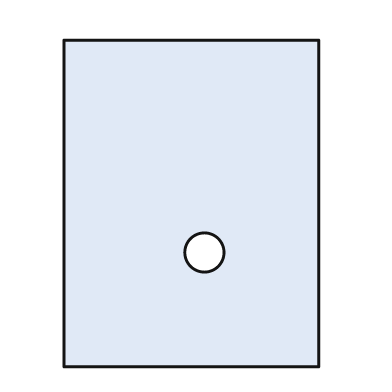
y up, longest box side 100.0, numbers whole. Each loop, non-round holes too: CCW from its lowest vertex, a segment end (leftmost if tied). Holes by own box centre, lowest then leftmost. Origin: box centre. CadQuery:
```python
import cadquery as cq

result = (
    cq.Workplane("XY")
    .moveTo(-39.0, -50.0)
    .lineTo(39.0, -50.0)
    .lineTo(39.0, 50.0)
    .lineTo(-39.0, 50.0)
    .close()
    .moveTo(4.0, -15.0)
    .circle(6.0)
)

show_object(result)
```